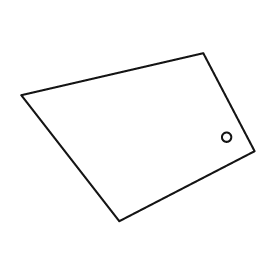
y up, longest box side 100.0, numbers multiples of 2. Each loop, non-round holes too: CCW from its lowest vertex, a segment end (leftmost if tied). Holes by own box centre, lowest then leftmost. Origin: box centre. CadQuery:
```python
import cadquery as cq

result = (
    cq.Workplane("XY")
    .moveTo(-8.0, -36.0)
    .lineTo(50.0, -6.0)
    .lineTo(28.0, 36.0)
    .lineTo(-50.0, 18.0)
    .close()
    .moveTo(38.0, 0.0)
    .circle(2.0)
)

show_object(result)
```